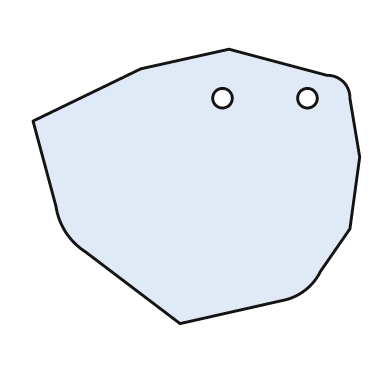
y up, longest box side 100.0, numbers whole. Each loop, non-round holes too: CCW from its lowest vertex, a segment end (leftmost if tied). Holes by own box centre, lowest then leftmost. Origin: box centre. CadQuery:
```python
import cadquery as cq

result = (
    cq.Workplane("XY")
    .moveTo(-5.0, -42.0)
    .lineTo(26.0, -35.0)
    .threePointArc((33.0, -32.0), (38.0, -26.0))
    .lineTo(47.0, -13.0)
    .lineTo(50.0, 9.0)
    .lineTo(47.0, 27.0)
    .threePointArc((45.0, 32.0), (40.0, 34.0))
    .lineTo(10.0, 42.0)
    .lineTo(-17.0, 36.0)
    .lineTo(-50.0, 20.0)
    .lineTo(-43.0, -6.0)
    .threePointArc((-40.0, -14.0), (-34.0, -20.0))
    .close()
    .moveTo(8.0, 27.0)
    .circle(3.0)
    .moveTo(34.0, 27.0)
    .circle(3.0)
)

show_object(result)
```